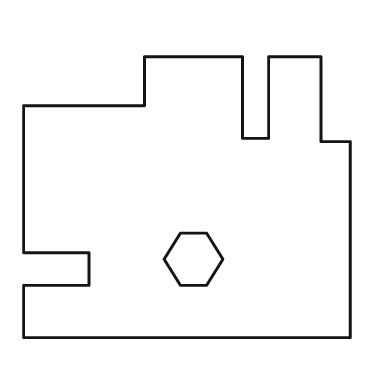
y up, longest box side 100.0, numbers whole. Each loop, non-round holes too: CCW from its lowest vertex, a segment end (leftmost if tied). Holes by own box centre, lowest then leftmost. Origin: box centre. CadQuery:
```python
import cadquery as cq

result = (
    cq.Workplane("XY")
    .moveTo(-50.0, -43.0)
    .lineTo(50.0, -43.0)
    .lineTo(50.0, 17.0)
    .lineTo(41.0, 17.0)
    .lineTo(41.0, 43.0)
    .lineTo(25.0, 43.0)
    .lineTo(25.0, 18.0)
    .lineTo(17.0, 18.0)
    .lineTo(17.0, 43.0)
    .lineTo(-13.0, 43.0)
    .lineTo(-13.0, 28.0)
    .lineTo(-50.0, 28.0)
    .lineTo(-50.0, -17.0)
    .lineTo(-30.0, -17.0)
    .lineTo(-30.0, -27.0)
    .lineTo(-50.0, -27.0)
    .close()
    .moveTo(-2.0, -27.0)
    .lineTo(6.0, -27.0)
    .lineTo(11.0, -19.0)
    .lineTo(6.0, -11.0)
    .lineTo(-2.0, -11.0)
    .lineTo(-7.0, -19.0)
    .close()
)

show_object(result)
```